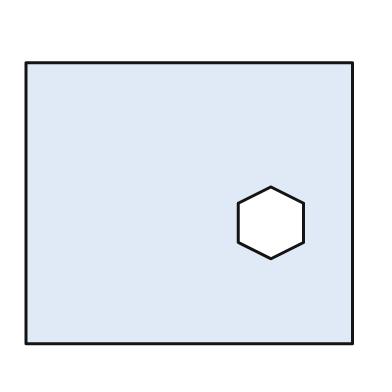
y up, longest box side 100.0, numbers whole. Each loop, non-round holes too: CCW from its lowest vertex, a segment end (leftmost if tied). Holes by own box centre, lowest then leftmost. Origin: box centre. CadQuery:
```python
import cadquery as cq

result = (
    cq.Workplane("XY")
    .moveTo(-50.0, -43.0)
    .lineTo(50.0, -43.0)
    .lineTo(50.0, 43.0)
    .lineTo(-50.0, 43.0)
    .close()
    .moveTo(25.0, -17.0)
    .lineTo(35.0, -12.0)
    .lineTo(35.0, 0.0)
    .lineTo(25.0, 5.0)
    .lineTo(15.0, 0.0)
    .lineTo(15.0, -12.0)
    .close()
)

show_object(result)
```